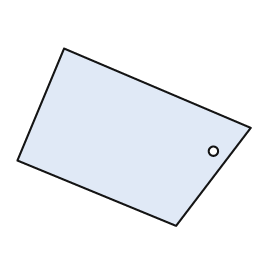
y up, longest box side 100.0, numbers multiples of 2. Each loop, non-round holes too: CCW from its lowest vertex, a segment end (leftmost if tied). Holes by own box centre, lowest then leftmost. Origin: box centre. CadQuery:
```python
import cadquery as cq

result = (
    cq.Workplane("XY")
    .moveTo(18.0, -38.0)
    .lineTo(50.0, 4.0)
    .lineTo(-30.0, 38.0)
    .lineTo(-50.0, -10.0)
    .close()
    .moveTo(34.0, -6.0)
    .circle(2.0)
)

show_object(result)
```